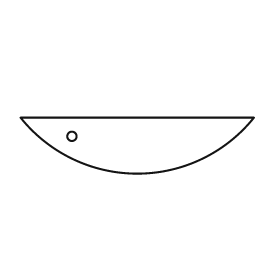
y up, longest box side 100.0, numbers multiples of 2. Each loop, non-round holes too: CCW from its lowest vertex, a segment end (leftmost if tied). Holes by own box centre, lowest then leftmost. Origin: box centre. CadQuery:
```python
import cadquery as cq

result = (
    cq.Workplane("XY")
    .moveTo(-50.0, 12.0)
    .threePointArc((0.0, -12.0), (50.0, 12.0))
    .close()
    .moveTo(-28.0, 4.0)
    .circle(2.0)
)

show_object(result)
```